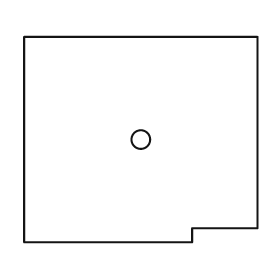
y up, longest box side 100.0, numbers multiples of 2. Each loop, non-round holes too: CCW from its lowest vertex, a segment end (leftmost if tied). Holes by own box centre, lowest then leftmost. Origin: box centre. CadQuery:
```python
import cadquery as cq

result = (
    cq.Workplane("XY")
    .moveTo(-50.0, -44.0)
    .lineTo(22.0, -44.0)
    .lineTo(22.0, -38.0)
    .lineTo(50.0, -38.0)
    .lineTo(50.0, 44.0)
    .lineTo(-50.0, 44.0)
    .close()
    .moveTo(0.0, 0.0)
    .circle(4.0)
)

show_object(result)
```